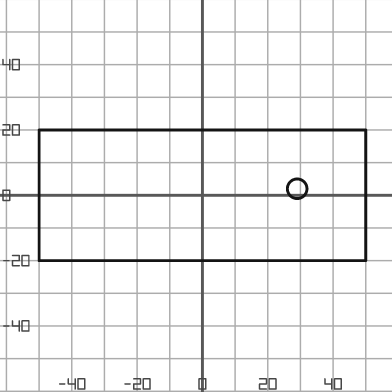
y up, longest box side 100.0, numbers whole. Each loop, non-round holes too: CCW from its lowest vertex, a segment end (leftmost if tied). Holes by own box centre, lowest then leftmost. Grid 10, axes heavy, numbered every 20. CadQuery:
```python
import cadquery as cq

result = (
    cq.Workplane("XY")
    .moveTo(-50.0, -20.0)
    .lineTo(50.0, -20.0)
    .lineTo(50.0, 20.0)
    .lineTo(-50.0, 20.0)
    .close()
    .moveTo(29.0, 2.0)
    .circle(3.0)
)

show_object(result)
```